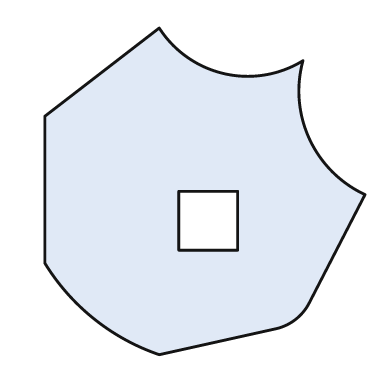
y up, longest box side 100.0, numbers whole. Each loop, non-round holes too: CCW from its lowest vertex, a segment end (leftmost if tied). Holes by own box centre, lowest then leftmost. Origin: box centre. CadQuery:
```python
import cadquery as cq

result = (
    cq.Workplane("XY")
    .moveTo(-14.0, -50.0)
    .lineTo(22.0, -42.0)
    .threePointArc((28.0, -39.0), (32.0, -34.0))
    .lineTo(49.0, -1.0)
    .threePointArc((32.0, 16.0), (30.0, 40.0))
    .threePointArc((6.0, 36.0), (-14.0, 50.0))
    .lineTo(-49.0, 23.0)
    .lineTo(-49.0, -22.0)
    .threePointArc((-34.0, -39.0), (-14.0, -50.0))
    .close()
    .moveTo(-8.0, -18.0)
    .lineTo(10.0, -18.0)
    .lineTo(10.0, 0.0)
    .lineTo(-8.0, 0.0)
    .close()
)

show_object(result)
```